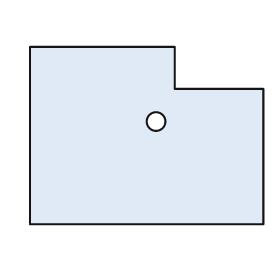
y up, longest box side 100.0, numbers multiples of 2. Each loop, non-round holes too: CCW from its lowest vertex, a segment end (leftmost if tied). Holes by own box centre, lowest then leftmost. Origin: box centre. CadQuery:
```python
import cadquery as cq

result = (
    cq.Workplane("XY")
    .moveTo(-50.0, -38.0)
    .lineTo(50.0, -38.0)
    .lineTo(50.0, 20.0)
    .lineTo(12.0, 20.0)
    .lineTo(12.0, 38.0)
    .lineTo(-50.0, 38.0)
    .close()
    .moveTo(4.0, 6.0)
    .circle(4.0)
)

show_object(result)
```